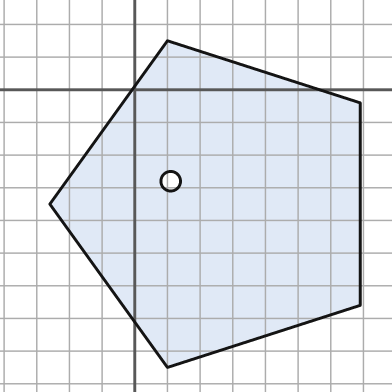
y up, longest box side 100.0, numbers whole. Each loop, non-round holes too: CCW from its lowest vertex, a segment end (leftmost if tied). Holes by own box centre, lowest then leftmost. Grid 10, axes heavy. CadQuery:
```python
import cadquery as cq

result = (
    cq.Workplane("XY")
    .moveTo(10.0, -85.0)
    .lineTo(69.0, -66.0)
    .lineTo(69.0, -4.0)
    .lineTo(10.0, 15.0)
    .lineTo(-26.0, -35.0)
    .close()
    .moveTo(11.0, -28.0)
    .circle(3.0)
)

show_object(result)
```